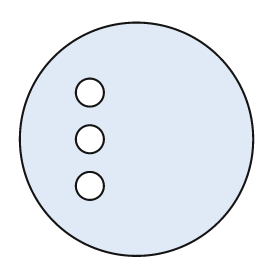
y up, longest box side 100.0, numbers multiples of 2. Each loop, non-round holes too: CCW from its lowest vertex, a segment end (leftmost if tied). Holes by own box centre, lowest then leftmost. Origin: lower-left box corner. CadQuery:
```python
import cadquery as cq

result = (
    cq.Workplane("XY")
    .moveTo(50.0, 50.0)
    .circle(50.0)
    .moveTo(30.0, 30.0)
    .circle(6.0)
    .moveTo(30.0, 50.0)
    .circle(6.0)
    .moveTo(30.0, 70.0)
    .circle(6.0)
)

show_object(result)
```